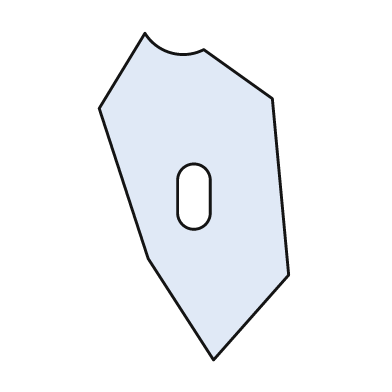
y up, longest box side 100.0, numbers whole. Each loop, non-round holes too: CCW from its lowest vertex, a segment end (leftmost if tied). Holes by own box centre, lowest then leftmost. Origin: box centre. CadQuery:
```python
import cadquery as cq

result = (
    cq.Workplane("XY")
    .moveTo(6.0, -50.0)
    .lineTo(29.0, -24.0)
    .lineTo(24.0, 30.0)
    .lineTo(3.0, 45.0)
    .threePointArc((-7.0, 44.0), (-15.0, 50.0))
    .lineTo(-29.0, 27.0)
    .lineTo(-14.0, -19.0)
    .close()
    .moveTo(-5.0, -5.0)
    .threePointArc((0.0, -10.0), (5.0, -5.0))
    .lineTo(5.0, 5.0)
    .threePointArc((0.0, 10.0), (-5.0, 5.0))
    .close()
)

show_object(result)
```